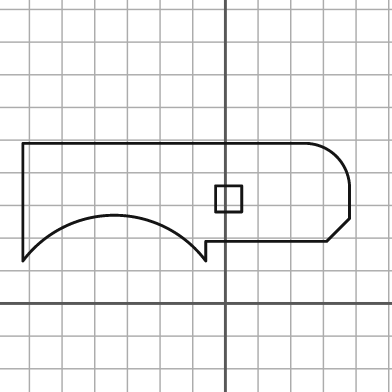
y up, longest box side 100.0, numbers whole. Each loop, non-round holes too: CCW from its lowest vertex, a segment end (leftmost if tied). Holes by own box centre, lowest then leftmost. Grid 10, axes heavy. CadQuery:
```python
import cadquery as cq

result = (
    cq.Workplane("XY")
    .moveTo(-62.0, 13.0)
    .threePointArc((-34.0, 27.0), (-6.0, 13.0))
    .lineTo(-6.0, 19.0)
    .lineTo(31.0, 19.0)
    .lineTo(38.0, 26.0)
    .lineTo(38.0, 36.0)
    .threePointArc((34.0, 45.0), (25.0, 49.0))
    .lineTo(-62.0, 49.0)
    .close()
    .moveTo(-3.0, 28.0)
    .lineTo(5.0, 28.0)
    .lineTo(5.0, 36.0)
    .lineTo(-3.0, 36.0)
    .close()
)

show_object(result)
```